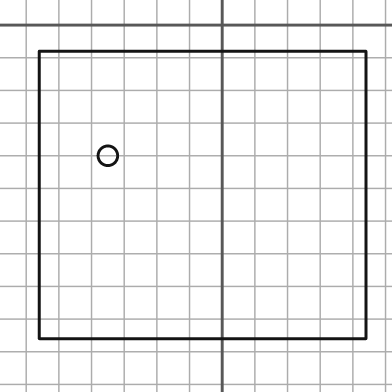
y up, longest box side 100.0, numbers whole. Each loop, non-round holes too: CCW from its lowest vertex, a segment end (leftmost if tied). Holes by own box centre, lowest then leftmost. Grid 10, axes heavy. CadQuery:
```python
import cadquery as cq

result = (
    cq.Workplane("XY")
    .moveTo(-56.0, -96.0)
    .lineTo(44.0, -96.0)
    .lineTo(44.0, -8.0)
    .lineTo(-56.0, -8.0)
    .close()
    .moveTo(-35.0, -40.0)
    .circle(3.0)
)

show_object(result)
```